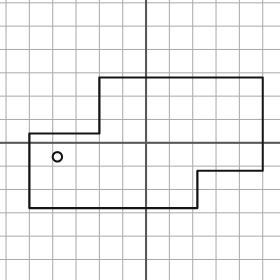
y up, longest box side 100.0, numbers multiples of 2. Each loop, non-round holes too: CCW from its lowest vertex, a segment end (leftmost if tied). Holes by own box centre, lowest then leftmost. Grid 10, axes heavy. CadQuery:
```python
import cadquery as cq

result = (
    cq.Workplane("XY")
    .moveTo(-50.0, -28.0)
    .lineTo(22.0, -28.0)
    .lineTo(22.0, -12.0)
    .lineTo(50.0, -12.0)
    .lineTo(50.0, 28.0)
    .lineTo(-20.0, 28.0)
    .lineTo(-20.0, 4.0)
    .lineTo(-50.0, 4.0)
    .close()
    .moveTo(-38.0, -6.0)
    .circle(2.0)
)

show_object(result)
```